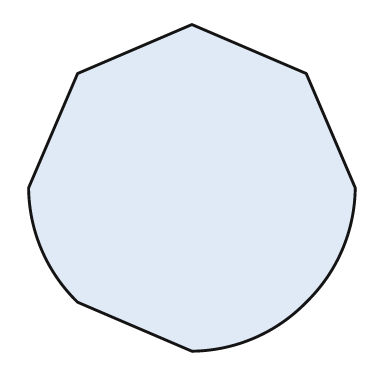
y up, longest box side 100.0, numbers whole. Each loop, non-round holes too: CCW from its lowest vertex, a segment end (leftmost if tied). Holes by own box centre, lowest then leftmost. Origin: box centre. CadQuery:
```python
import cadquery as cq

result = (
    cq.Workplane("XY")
    .moveTo(0.0, -50.0)
    .threePointArc((19.0, -46.0), (35.0, -35.0))
    .threePointArc((46.0, -19.0), (50.0, 0.0))
    .lineTo(35.0, 35.0)
    .lineTo(0.0, 50.0)
    .lineTo(-35.0, 35.0)
    .lineTo(-50.0, 0.0)
    .threePointArc((-46.0, -19.0), (-35.0, -35.0))
    .close()
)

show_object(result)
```